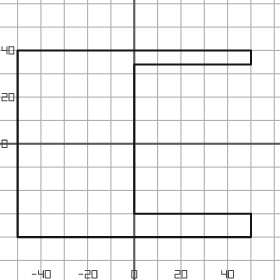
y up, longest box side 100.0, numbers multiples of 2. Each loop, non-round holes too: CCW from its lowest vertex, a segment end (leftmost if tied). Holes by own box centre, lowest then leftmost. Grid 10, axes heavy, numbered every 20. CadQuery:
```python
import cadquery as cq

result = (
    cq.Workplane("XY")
    .moveTo(-50.0, -40.0)
    .lineTo(50.0, -40.0)
    .lineTo(50.0, -30.0)
    .lineTo(0.0, -30.0)
    .lineTo(0.0, 34.0)
    .lineTo(50.0, 34.0)
    .lineTo(50.0, 40.0)
    .lineTo(-50.0, 40.0)
    .close()
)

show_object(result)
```